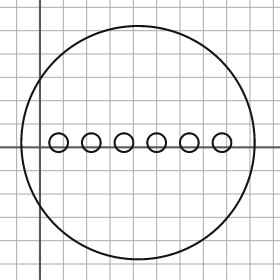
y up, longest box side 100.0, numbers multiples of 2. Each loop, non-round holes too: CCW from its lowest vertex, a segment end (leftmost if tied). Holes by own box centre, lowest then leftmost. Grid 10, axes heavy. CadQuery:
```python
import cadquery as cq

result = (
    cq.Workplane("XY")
    .moveTo(42.0, 2.0)
    .circle(50.0)
    .moveTo(8.0, 2.0)
    .circle(4.0)
    .moveTo(22.0, 2.0)
    .circle(4.0)
    .moveTo(36.0, 2.0)
    .circle(4.0)
    .moveTo(50.0, 2.0)
    .circle(4.0)
    .moveTo(64.0, 2.0)
    .circle(4.0)
    .moveTo(78.0, 2.0)
    .circle(4.0)
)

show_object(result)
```